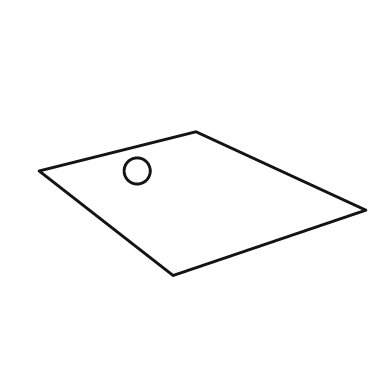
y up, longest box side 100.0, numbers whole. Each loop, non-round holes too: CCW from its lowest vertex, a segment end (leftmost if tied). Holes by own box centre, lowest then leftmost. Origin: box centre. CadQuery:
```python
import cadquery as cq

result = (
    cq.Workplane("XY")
    .moveTo(-9.0, -22.0)
    .lineTo(50.0, -2.0)
    .lineTo(-2.0, 22.0)
    .lineTo(-50.0, 10.0)
    .close()
    .moveTo(-20.0, 10.0)
    .circle(4.0)
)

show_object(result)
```